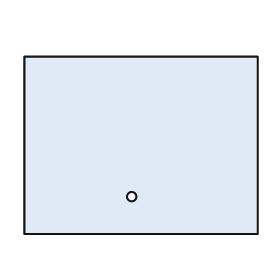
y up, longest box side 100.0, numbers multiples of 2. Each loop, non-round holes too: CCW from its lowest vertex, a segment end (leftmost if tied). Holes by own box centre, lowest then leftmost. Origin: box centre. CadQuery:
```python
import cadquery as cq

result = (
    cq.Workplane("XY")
    .moveTo(-50.0, -38.0)
    .lineTo(50.0, -38.0)
    .lineTo(50.0, 38.0)
    .lineTo(-50.0, 38.0)
    .close()
    .moveTo(-4.0, -22.0)
    .circle(2.0)
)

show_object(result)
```